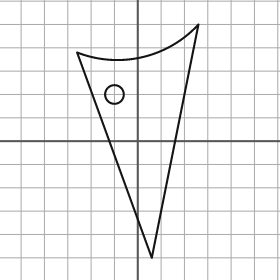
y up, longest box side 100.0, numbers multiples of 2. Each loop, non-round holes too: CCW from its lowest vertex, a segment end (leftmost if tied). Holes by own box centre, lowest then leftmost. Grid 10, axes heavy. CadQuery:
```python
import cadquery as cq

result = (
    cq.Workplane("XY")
    .moveTo(6.0, -50.0)
    .lineTo(26.0, 50.0)
    .threePointArc((2.0, 36.0), (-26.0, 38.0))
    .close()
    .moveTo(-10.0, 20.0)
    .circle(4.0)
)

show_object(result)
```